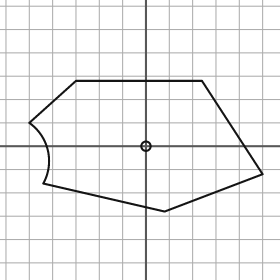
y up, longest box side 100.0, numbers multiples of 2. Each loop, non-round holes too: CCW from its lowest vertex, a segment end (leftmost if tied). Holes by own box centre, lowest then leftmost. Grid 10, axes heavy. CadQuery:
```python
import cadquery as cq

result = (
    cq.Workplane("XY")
    .moveTo(8.0, -28.0)
    .lineTo(50.0, -12.0)
    .lineTo(24.0, 28.0)
    .lineTo(-30.0, 28.0)
    .lineTo(-50.0, 10.0)
    .threePointArc((-42.0, -2.0), (-44.0, -16.0))
    .close()
    .moveTo(0.0, 0.0)
    .circle(2.0)
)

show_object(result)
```